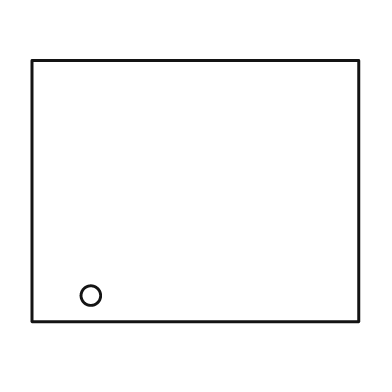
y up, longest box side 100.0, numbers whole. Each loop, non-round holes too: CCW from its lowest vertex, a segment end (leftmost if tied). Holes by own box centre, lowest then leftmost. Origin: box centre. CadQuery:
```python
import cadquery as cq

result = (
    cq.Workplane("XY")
    .moveTo(-50.0, -40.0)
    .lineTo(50.0, -40.0)
    .lineTo(50.0, 40.0)
    .lineTo(-50.0, 40.0)
    .close()
    .moveTo(-32.0, -32.0)
    .circle(3.0)
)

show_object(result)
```